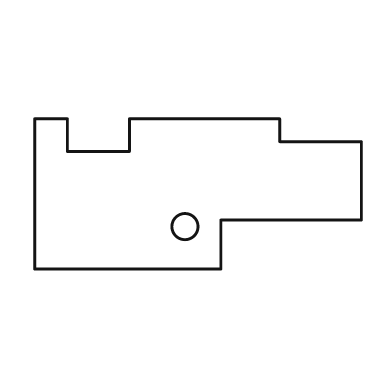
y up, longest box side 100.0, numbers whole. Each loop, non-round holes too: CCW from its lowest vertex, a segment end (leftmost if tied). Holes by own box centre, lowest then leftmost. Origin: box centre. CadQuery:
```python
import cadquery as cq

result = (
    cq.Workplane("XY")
    .moveTo(-50.0, -23.0)
    .lineTo(7.0, -23.0)
    .lineTo(7.0, -8.0)
    .lineTo(50.0, -8.0)
    .lineTo(50.0, 16.0)
    .lineTo(25.0, 16.0)
    .lineTo(25.0, 23.0)
    .lineTo(-21.0, 23.0)
    .lineTo(-21.0, 13.0)
    .lineTo(-40.0, 13.0)
    .lineTo(-40.0, 23.0)
    .lineTo(-50.0, 23.0)
    .close()
    .moveTo(-4.0, -10.0)
    .circle(4.0)
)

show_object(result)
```